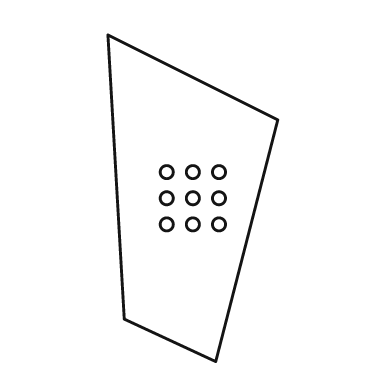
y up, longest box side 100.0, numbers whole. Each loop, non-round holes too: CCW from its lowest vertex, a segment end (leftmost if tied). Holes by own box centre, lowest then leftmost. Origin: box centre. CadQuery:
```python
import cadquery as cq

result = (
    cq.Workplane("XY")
    .moveTo(7.0, -50.0)
    .lineTo(26.0, 24.0)
    .lineTo(-26.0, 50.0)
    .lineTo(-21.0, -37.0)
    .close()
    .moveTo(-8.0, -8.0)
    .circle(2.0)
    .moveTo(0.0, -8.0)
    .circle(2.0)
    .moveTo(8.0, -8.0)
    .circle(2.0)
    .moveTo(-8.0, 0.0)
    .circle(2.0)
    .moveTo(0.0, 0.0)
    .circle(2.0)
    .moveTo(8.0, 0.0)
    .circle(2.0)
    .moveTo(-8.0, 8.0)
    .circle(2.0)
    .moveTo(0.0, 8.0)
    .circle(2.0)
    .moveTo(8.0, 8.0)
    .circle(2.0)
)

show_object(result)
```